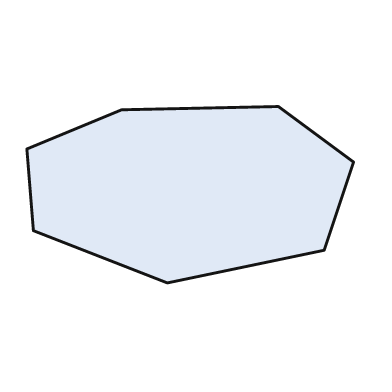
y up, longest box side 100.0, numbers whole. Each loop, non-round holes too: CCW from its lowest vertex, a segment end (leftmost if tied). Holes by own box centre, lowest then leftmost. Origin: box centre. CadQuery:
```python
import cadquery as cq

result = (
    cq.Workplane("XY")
    .moveTo(-7.0, -27.0)
    .lineTo(41.0, -17.0)
    .lineTo(50.0, 10.0)
    .lineTo(27.0, 27.0)
    .lineTo(-21.0, 26.0)
    .lineTo(-50.0, 14.0)
    .lineTo(-48.0, -11.0)
    .close()
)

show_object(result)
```